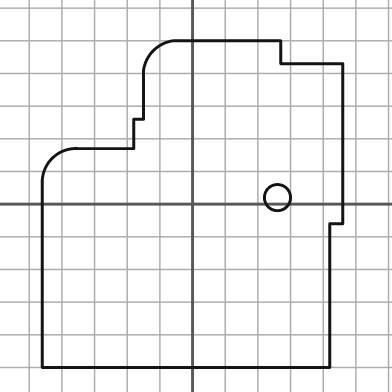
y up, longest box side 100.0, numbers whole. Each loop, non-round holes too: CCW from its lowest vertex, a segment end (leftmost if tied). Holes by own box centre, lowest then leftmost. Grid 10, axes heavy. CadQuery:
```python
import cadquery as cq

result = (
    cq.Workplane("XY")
    .moveTo(-46.0, -50.0)
    .lineTo(42.0, -50.0)
    .lineTo(42.0, -6.0)
    .lineTo(46.0, -6.0)
    .lineTo(46.0, 43.0)
    .lineTo(27.0, 43.0)
    .lineTo(27.0, 50.0)
    .lineTo(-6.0, 50.0)
    .threePointArc((-12.0, 47.0), (-15.0, 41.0))
    .lineTo(-15.0, 26.0)
    .lineTo(-18.0, 26.0)
    .lineTo(-18.0, 17.0)
    .lineTo(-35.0, 17.0)
    .threePointArc((-43.0, 14.0), (-46.0, 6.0))
    .close()
    .moveTo(26.0, 2.0)
    .circle(4.0)
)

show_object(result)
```